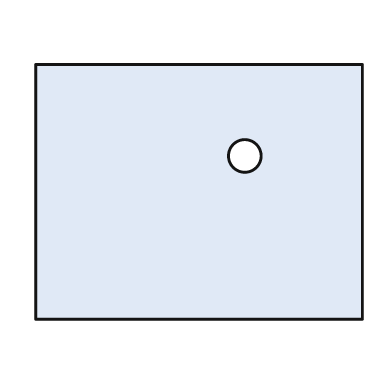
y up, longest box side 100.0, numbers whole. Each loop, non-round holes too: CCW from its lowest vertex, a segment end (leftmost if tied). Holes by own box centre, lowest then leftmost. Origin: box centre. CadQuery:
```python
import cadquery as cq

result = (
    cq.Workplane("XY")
    .moveTo(-50.0, -39.0)
    .lineTo(50.0, -39.0)
    .lineTo(50.0, 39.0)
    .lineTo(-50.0, 39.0)
    .close()
    .moveTo(14.0, 11.0)
    .circle(5.0)
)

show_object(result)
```